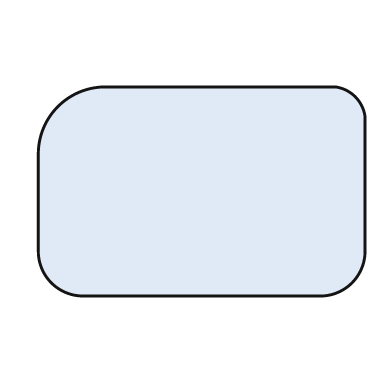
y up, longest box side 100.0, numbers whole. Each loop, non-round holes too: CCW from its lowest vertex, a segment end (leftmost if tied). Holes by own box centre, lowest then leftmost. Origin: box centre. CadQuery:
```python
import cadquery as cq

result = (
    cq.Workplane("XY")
    .moveTo(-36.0, -32.0)
    .lineTo(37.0, -32.0)
    .threePointArc((46.0, -28.0), (50.0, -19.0))
    .lineTo(50.0, 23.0)
    .threePointArc((47.0, 29.0), (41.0, 32.0))
    .lineTo(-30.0, 32.0)
    .threePointArc((-44.0, 26.0), (-50.0, 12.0))
    .lineTo(-50.0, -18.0)
    .threePointArc((-46.0, -28.0), (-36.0, -32.0))
    .close()
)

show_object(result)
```